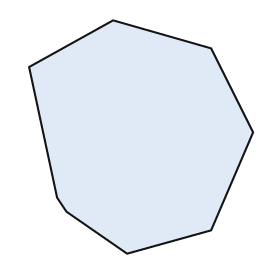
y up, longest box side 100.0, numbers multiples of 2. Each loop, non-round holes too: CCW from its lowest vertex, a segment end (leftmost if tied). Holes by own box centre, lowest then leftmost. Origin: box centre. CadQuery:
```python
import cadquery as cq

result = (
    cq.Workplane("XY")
    .moveTo(-6.0, -50.0)
    .lineTo(30.0, -40.0)
    .lineTo(48.0, 2.0)
    .lineTo(30.0, 38.0)
    .lineTo(-12.0, 50.0)
    .lineTo(-48.0, 30.0)
    .lineTo(-36.0, -26.0)
    .lineTo(-32.0, -32.0)
    .close()
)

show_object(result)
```